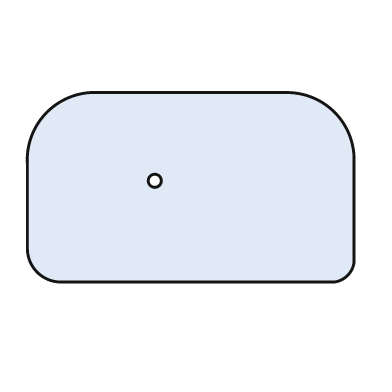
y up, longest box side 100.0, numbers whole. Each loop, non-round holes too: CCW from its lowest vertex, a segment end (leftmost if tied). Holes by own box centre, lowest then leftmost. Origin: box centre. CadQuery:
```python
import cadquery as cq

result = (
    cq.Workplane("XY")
    .moveTo(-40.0, -29.0)
    .lineTo(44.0, -29.0)
    .threePointArc((48.0, -27.0), (50.0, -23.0))
    .lineTo(50.0, 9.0)
    .threePointArc((44.0, 23.0), (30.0, 29.0))
    .lineTo(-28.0, 29.0)
    .threePointArc((-44.0, 23.0), (-50.0, 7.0))
    .lineTo(-50.0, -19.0)
    .threePointArc((-47.0, -26.0), (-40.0, -29.0))
    .close()
    .moveTo(-11.0, 2.0)
    .circle(2.0)
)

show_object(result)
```